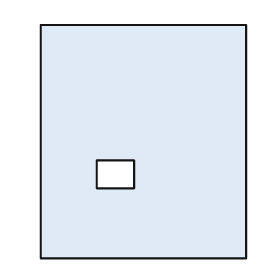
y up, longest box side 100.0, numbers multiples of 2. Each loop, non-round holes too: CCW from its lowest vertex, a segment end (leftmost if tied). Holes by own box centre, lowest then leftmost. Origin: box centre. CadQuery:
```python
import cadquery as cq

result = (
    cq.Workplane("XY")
    .moveTo(-44.0, -50.0)
    .lineTo(44.0, -50.0)
    .lineTo(44.0, 50.0)
    .lineTo(-44.0, 50.0)
    .close()
    .moveTo(-20.0, -20.0)
    .lineTo(-4.0, -20.0)
    .lineTo(-4.0, -8.0)
    .lineTo(-20.0, -8.0)
    .close()
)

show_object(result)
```